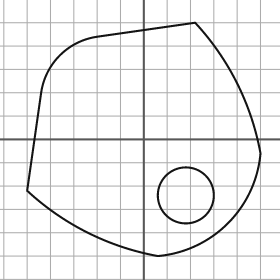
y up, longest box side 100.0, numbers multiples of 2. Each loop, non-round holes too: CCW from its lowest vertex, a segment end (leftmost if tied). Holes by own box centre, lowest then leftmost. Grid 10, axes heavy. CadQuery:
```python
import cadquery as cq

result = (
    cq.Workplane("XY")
    .moveTo(6.0, -50.0)
    .threePointArc((36.0, -36.0), (50.0, -6.0))
    .threePointArc((40.0, 24.0), (22.0, 50.0))
    .lineTo(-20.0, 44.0)
    .threePointArc((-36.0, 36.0), (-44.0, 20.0))
    .lineTo(-50.0, -22.0)
    .threePointArc((-24.0, -40.0), (6.0, -50.0))
    .close()
    .moveTo(18.0, -24.0)
    .circle(12.0)
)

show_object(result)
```